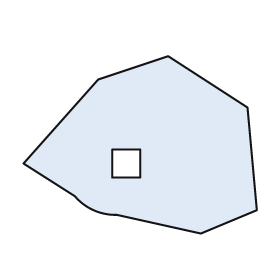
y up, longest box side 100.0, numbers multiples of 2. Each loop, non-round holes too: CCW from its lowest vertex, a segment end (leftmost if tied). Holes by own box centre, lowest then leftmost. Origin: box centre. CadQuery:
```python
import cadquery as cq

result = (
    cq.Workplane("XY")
    .moveTo(26.0, -38.0)
    .lineTo(50.0, -28.0)
    .lineTo(46.0, 16.0)
    .lineTo(12.0, 38.0)
    .lineTo(-18.0, 28.0)
    .lineTo(-50.0, -8.0)
    .lineTo(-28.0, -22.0)
    .threePointArc((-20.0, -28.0), (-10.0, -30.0))
    .close()
    .moveTo(-12.0, -14.0)
    .lineTo(0.0, -14.0)
    .lineTo(0.0, -2.0)
    .lineTo(-12.0, -2.0)
    .close()
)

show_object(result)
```